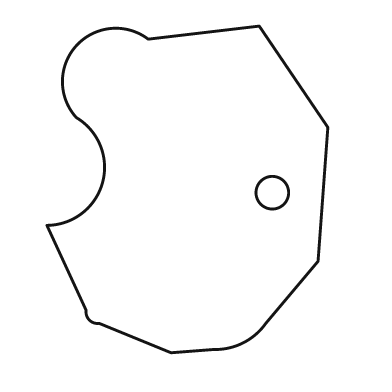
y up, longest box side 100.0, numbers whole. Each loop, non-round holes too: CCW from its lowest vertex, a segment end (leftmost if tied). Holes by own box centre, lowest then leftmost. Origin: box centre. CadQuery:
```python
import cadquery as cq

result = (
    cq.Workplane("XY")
    .moveTo(-5.0, -50.0)
    .lineTo(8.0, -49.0)
    .threePointArc((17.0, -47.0), (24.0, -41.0))
    .lineTo(40.0, -22.0)
    .lineTo(43.0, 19.0)
    .lineTo(22.0, 50.0)
    .lineTo(-12.0, 46.0)
    .threePointArc((-34.0, 44.0), (-34.0, 22.0))
    .threePointArc((-26.0, 2.0), (-43.0, -11.0))
    .lineTo(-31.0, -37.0)
    .threePointArc((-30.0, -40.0), (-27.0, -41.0))
    .close()
    .moveTo(26.0, -1.0)
    .circle(5.0)
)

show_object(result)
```